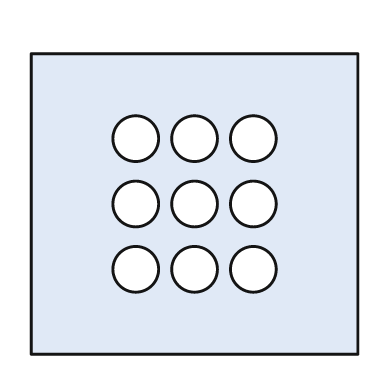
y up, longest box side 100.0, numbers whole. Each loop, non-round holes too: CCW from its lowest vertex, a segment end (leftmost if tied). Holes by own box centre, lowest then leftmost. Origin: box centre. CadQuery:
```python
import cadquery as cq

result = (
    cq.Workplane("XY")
    .moveTo(-50.0, -46.0)
    .lineTo(50.0, -46.0)
    .lineTo(50.0, 46.0)
    .lineTo(-50.0, 46.0)
    .close()
    .moveTo(-18.0, -20.0)
    .circle(7.0)
    .moveTo(0.0, -20.0)
    .circle(7.0)
    .moveTo(18.0, -20.0)
    .circle(7.0)
    .moveTo(-18.0, 0.0)
    .circle(7.0)
    .moveTo(0.0, 0.0)
    .circle(7.0)
    .moveTo(18.0, 0.0)
    .circle(7.0)
    .moveTo(-18.0, 20.0)
    .circle(7.0)
    .moveTo(0.0, 20.0)
    .circle(7.0)
    .moveTo(18.0, 20.0)
    .circle(7.0)
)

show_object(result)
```